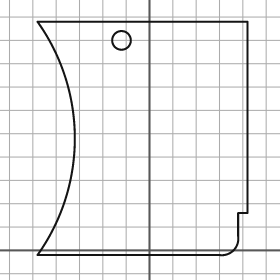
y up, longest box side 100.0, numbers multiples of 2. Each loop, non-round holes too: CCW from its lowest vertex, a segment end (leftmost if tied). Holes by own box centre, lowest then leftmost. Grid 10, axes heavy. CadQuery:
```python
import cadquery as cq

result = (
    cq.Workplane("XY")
    .moveTo(-48.0, -2.0)
    .lineTo(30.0, -2.0)
    .threePointArc((36.0, 0.0), (38.0, 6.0))
    .lineTo(38.0, 16.0)
    .lineTo(42.0, 16.0)
    .lineTo(42.0, 98.0)
    .lineTo(-48.0, 98.0)
    .threePointArc((-32.0, 48.0), (-48.0, -2.0))
    .close()
    .moveTo(-12.0, 90.0)
    .circle(4.0)
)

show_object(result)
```